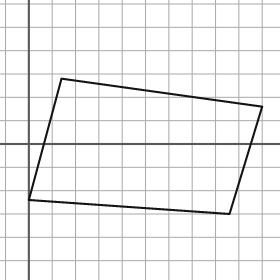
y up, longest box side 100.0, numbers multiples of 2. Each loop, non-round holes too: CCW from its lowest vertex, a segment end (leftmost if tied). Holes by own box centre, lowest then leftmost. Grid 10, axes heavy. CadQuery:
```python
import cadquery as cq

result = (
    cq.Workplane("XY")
    .moveTo(86.0, -30.0)
    .lineTo(100.0, 16.0)
    .lineTo(14.0, 28.0)
    .lineTo(0.0, -24.0)
    .close()
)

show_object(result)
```